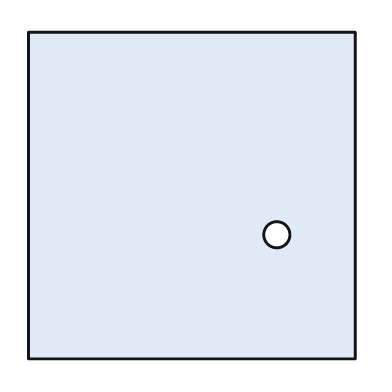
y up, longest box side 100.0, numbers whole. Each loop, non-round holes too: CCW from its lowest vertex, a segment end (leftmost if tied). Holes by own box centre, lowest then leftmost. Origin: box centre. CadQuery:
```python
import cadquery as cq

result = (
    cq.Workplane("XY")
    .moveTo(-50.0, -50.0)
    .lineTo(50.0, -50.0)
    .lineTo(50.0, 50.0)
    .lineTo(-50.0, 50.0)
    .close()
    .moveTo(26.0, -12.0)
    .circle(4.0)
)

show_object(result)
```